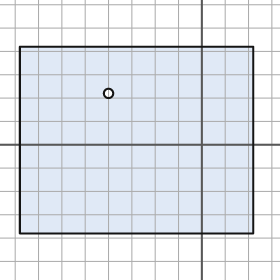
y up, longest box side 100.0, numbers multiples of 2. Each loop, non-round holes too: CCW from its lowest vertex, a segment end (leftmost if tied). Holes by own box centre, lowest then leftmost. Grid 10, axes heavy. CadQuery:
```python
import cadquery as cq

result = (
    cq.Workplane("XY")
    .moveTo(-78.0, -38.0)
    .lineTo(22.0, -38.0)
    .lineTo(22.0, 42.0)
    .lineTo(-78.0, 42.0)
    .close()
    .moveTo(-40.0, 22.0)
    .circle(2.0)
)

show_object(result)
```